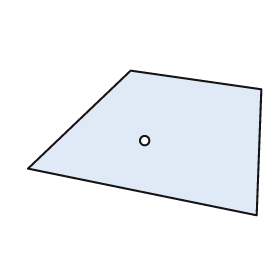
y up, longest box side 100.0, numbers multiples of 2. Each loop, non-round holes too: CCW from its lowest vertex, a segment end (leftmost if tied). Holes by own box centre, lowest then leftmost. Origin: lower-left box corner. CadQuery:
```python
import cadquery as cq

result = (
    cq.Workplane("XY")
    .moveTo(98.0, 0.0)
    .lineTo(100.0, 54.0)
    .lineTo(44.0, 62.0)
    .lineTo(0.0, 20.0)
    .close()
    .moveTo(50.0, 32.0)
    .circle(2.0)
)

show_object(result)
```